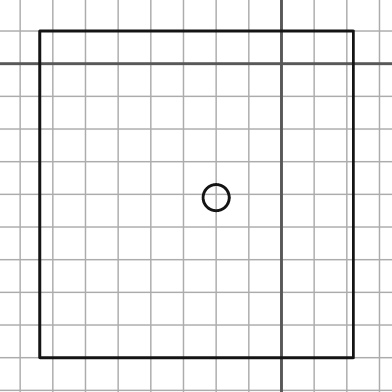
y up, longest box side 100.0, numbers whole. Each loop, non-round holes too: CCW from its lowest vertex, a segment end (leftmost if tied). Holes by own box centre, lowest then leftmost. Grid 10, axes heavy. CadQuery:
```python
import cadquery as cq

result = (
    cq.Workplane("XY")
    .moveTo(-74.0, -90.0)
    .lineTo(22.0, -90.0)
    .lineTo(22.0, 10.0)
    .lineTo(-74.0, 10.0)
    .close()
    .moveTo(-20.0, -41.0)
    .circle(4.0)
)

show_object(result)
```